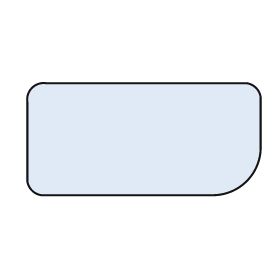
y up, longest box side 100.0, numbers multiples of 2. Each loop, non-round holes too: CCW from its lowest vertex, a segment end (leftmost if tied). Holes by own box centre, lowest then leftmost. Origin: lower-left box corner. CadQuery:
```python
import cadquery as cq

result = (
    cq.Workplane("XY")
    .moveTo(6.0, 0.0)
    .lineTo(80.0, 0.0)
    .threePointArc((94.0, 6.0), (100.0, 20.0))
    .lineTo(100.0, 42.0)
    .threePointArc((98.0, 46.0), (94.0, 48.0))
    .lineTo(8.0, 48.0)
    .threePointArc((2.0, 46.0), (0.0, 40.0))
    .lineTo(0.0, 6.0)
    .threePointArc((2.0, 2.0), (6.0, 0.0))
    .close()
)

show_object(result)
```